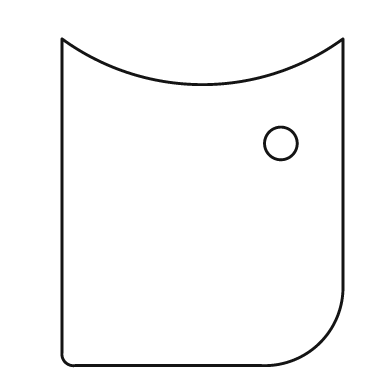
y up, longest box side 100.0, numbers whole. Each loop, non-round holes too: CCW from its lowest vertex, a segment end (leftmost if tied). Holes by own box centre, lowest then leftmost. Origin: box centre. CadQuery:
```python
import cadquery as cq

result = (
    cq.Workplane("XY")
    .moveTo(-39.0, -50.0)
    .lineTo(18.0, -50.0)
    .threePointArc((36.0, -43.0), (43.0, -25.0))
    .lineTo(43.0, 50.0)
    .threePointArc((0.0, 36.0), (-43.0, 50.0))
    .lineTo(-43.0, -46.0)
    .threePointArc((-42.0, -49.0), (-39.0, -50.0))
    .close()
    .moveTo(24.0, 18.0)
    .circle(5.0)
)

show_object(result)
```